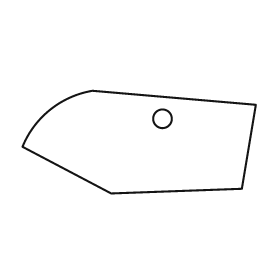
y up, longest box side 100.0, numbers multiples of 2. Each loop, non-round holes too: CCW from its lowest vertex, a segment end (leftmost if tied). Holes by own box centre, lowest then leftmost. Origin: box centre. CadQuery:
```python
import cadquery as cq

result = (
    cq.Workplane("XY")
    .moveTo(-12.0, -22.0)
    .lineTo(44.0, -20.0)
    .lineTo(50.0, 16.0)
    .lineTo(-20.0, 22.0)
    .threePointArc((-38.0, 14.0), (-50.0, -2.0))
    .close()
    .moveTo(10.0, 10.0)
    .circle(4.0)
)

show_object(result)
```